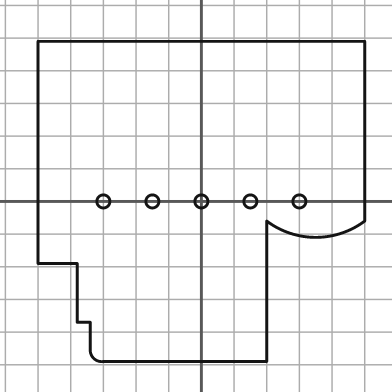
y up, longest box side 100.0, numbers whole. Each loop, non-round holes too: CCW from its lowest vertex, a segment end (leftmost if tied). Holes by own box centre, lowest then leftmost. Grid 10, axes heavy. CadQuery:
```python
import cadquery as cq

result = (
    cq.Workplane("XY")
    .moveTo(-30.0, -49.0)
    .lineTo(20.0, -49.0)
    .lineTo(20.0, -6.0)
    .threePointArc((35.0, -11.0), (50.0, -6.0))
    .lineTo(50.0, 49.0)
    .lineTo(-50.0, 49.0)
    .lineTo(-50.0, -19.0)
    .lineTo(-38.0, -19.0)
    .lineTo(-38.0, -37.0)
    .lineTo(-34.0, -37.0)
    .lineTo(-34.0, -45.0)
    .threePointArc((-33.0, -48.0), (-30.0, -49.0))
    .close()
    .moveTo(-30.0, 0.0)
    .circle(2.0)
    .moveTo(-15.0, 0.0)
    .circle(2.0)
    .moveTo(0.0, 0.0)
    .circle(2.0)
    .moveTo(15.0, 0.0)
    .circle(2.0)
    .moveTo(30.0, 0.0)
    .circle(2.0)
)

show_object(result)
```